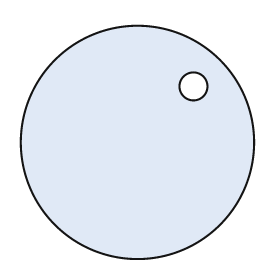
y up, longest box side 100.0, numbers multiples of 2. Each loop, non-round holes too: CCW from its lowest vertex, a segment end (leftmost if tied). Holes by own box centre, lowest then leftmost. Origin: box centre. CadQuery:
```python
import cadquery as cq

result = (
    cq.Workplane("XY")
    .moveTo(0.0, 0.0)
    .circle(50.0)
    .moveTo(24.0, 24.0)
    .circle(6.0)
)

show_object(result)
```